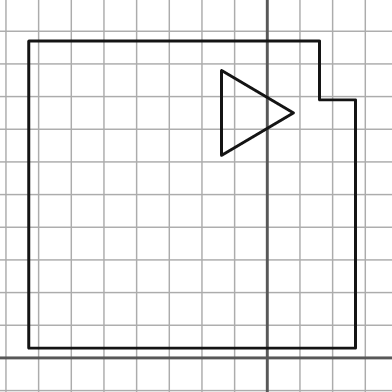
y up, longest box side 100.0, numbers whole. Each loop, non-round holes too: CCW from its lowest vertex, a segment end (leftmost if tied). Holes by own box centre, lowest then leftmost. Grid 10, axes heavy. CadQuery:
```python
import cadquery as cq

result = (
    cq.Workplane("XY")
    .moveTo(-73.0, 3.0)
    .lineTo(27.0, 3.0)
    .lineTo(27.0, 79.0)
    .lineTo(16.0, 79.0)
    .lineTo(16.0, 97.0)
    .lineTo(-73.0, 97.0)
    .close()
    .moveTo(-14.0, 62.0)
    .lineTo(8.0, 75.0)
    .lineTo(-14.0, 88.0)
    .close()
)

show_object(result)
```